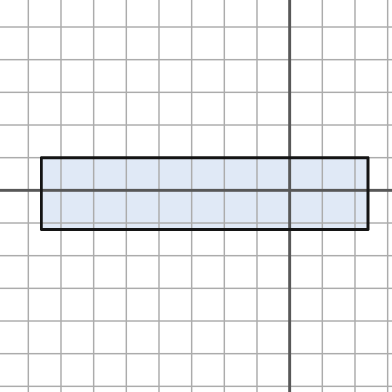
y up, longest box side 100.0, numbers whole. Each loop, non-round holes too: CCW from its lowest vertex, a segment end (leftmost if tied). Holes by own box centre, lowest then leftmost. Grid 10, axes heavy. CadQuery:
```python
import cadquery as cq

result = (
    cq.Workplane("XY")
    .moveTo(-76.0, -12.0)
    .lineTo(24.0, -12.0)
    .lineTo(24.0, 10.0)
    .lineTo(-76.0, 10.0)
    .close()
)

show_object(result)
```